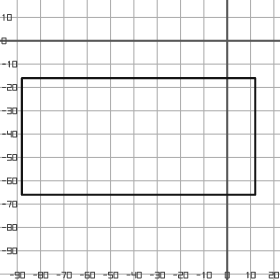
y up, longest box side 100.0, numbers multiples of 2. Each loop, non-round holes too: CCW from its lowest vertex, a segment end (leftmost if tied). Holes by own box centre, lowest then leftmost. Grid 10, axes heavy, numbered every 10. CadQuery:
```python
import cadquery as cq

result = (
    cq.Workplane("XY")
    .moveTo(-88.0, -66.0)
    .lineTo(12.0, -66.0)
    .lineTo(12.0, -16.0)
    .lineTo(-88.0, -16.0)
    .close()
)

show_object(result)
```